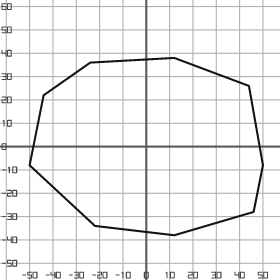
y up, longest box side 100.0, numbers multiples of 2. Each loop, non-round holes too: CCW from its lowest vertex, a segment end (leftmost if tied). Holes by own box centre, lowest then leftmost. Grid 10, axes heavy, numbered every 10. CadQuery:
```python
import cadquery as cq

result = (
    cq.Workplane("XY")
    .moveTo(12.0, -38.0)
    .lineTo(46.0, -28.0)
    .lineTo(50.0, -8.0)
    .lineTo(44.0, 26.0)
    .lineTo(12.0, 38.0)
    .lineTo(-24.0, 36.0)
    .lineTo(-44.0, 22.0)
    .lineTo(-50.0, -8.0)
    .lineTo(-22.0, -34.0)
    .close()
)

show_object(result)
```